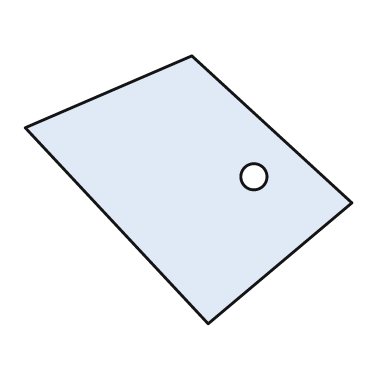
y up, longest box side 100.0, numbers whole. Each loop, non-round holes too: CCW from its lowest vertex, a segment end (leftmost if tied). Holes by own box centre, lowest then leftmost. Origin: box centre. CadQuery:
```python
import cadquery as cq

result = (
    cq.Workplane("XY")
    .moveTo(6.0, -41.0)
    .lineTo(50.0, -4.0)
    .lineTo(1.0, 41.0)
    .lineTo(-50.0, 19.0)
    .close()
    .moveTo(20.0, 4.0)
    .circle(4.0)
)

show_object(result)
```